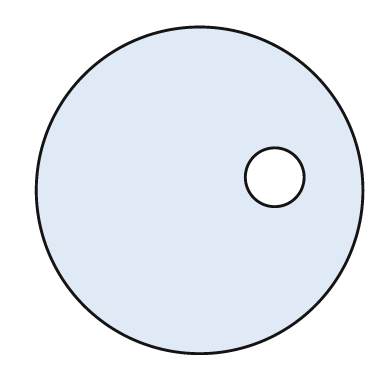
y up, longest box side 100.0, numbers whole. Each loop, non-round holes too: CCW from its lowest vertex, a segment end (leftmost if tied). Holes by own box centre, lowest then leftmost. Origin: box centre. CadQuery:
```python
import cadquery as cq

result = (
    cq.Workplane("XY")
    .moveTo(0.0, 0.0)
    .circle(50.0)
    .moveTo(23.0, 4.0)
    .circle(9.0)
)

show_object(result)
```